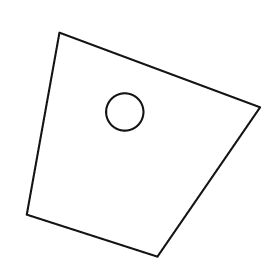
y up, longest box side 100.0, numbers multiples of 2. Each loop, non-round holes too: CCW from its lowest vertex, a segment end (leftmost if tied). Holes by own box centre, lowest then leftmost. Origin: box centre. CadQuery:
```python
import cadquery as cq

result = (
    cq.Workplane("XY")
    .moveTo(6.0, -48.0)
    .lineTo(50.0, 16.0)
    .lineTo(-36.0, 48.0)
    .lineTo(-50.0, -30.0)
    .close()
    .moveTo(-8.0, 14.0)
    .circle(8.0)
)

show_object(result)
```